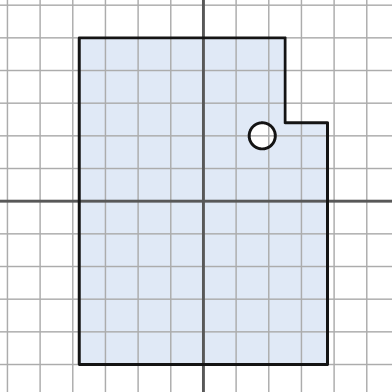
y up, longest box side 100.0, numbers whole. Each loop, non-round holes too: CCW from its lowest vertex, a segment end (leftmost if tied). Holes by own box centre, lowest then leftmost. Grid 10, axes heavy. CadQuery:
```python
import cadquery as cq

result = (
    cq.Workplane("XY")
    .moveTo(-38.0, -50.0)
    .lineTo(38.0, -50.0)
    .lineTo(38.0, 24.0)
    .lineTo(25.0, 24.0)
    .lineTo(25.0, 50.0)
    .lineTo(-38.0, 50.0)
    .close()
    .moveTo(18.0, 20.0)
    .circle(4.0)
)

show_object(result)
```